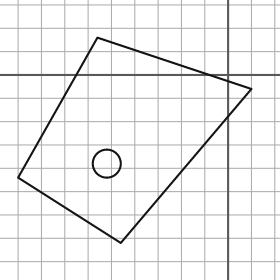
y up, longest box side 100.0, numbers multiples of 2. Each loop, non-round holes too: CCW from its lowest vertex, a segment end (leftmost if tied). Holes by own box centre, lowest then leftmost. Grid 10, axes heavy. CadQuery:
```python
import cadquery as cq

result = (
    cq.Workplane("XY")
    .moveTo(-46.0, -72.0)
    .lineTo(10.0, -6.0)
    .lineTo(-56.0, 16.0)
    .lineTo(-90.0, -44.0)
    .close()
    .moveTo(-52.0, -38.0)
    .circle(6.0)
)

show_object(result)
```